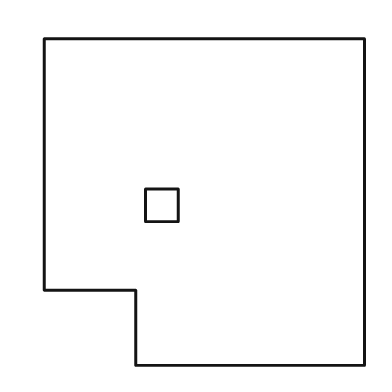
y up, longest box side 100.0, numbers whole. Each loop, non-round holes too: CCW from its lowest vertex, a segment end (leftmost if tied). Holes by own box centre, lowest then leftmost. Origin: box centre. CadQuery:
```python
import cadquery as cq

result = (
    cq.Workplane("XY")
    .moveTo(-21.0, -50.0)
    .lineTo(49.0, -50.0)
    .lineTo(49.0, 50.0)
    .lineTo(-49.0, 50.0)
    .lineTo(-49.0, -27.0)
    .lineTo(-21.0, -27.0)
    .close()
    .moveTo(-18.0, -6.0)
    .lineTo(-8.0, -6.0)
    .lineTo(-8.0, 4.0)
    .lineTo(-18.0, 4.0)
    .close()
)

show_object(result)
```